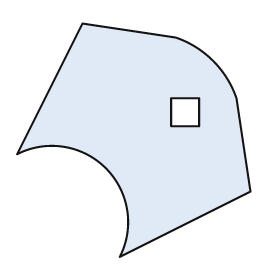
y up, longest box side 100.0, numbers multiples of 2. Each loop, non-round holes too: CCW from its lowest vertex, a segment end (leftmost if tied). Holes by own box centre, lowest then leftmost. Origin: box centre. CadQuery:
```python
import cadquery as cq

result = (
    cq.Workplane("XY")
    .moveTo(-6.0, -50.0)
    .lineTo(50.0, -22.0)
    .lineTo(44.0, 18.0)
    .threePointArc((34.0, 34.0), (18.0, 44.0))
    .lineTo(-22.0, 50.0)
    .lineTo(-50.0, -6.0)
    .threePointArc((-12.0, -12.0), (-6.0, -50.0))
    .close()
    .moveTo(16.0, 6.0)
    .lineTo(28.0, 6.0)
    .lineTo(28.0, 18.0)
    .lineTo(16.0, 18.0)
    .close()
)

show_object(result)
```